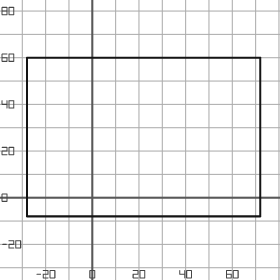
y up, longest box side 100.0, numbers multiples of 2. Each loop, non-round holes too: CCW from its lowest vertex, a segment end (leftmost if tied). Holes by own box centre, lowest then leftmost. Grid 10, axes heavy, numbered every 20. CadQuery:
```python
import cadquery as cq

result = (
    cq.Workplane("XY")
    .moveTo(-28.0, -8.0)
    .lineTo(72.0, -8.0)
    .lineTo(72.0, 60.0)
    .lineTo(-28.0, 60.0)
    .close()
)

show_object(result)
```